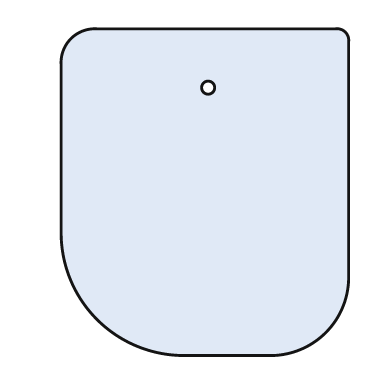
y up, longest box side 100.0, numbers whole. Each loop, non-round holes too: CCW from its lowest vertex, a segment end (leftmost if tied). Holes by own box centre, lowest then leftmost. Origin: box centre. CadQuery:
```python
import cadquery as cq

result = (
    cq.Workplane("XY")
    .moveTo(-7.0, -50.0)
    .lineTo(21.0, -50.0)
    .threePointArc((37.0, -43.0), (44.0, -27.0))
    .lineTo(44.0, 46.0)
    .threePointArc((43.0, 49.0), (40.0, 50.0))
    .lineTo(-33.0, 50.0)
    .threePointArc((-41.0, 47.0), (-44.0, 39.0))
    .lineTo(-44.0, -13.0)
    .threePointArc((-33.0, -39.0), (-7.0, -50.0))
    .close()
    .moveTo(1.0, 32.0)
    .circle(2.0)
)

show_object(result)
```